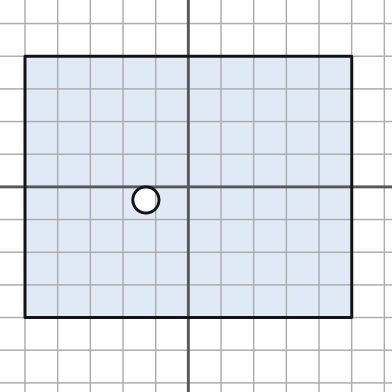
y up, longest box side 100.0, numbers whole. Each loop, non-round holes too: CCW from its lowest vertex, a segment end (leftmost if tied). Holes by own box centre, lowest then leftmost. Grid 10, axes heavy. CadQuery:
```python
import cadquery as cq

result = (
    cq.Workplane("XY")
    .moveTo(-50.0, -40.0)
    .lineTo(50.0, -40.0)
    .lineTo(50.0, 40.0)
    .lineTo(-50.0, 40.0)
    .close()
    .moveTo(-13.0, -4.0)
    .circle(4.0)
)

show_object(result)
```